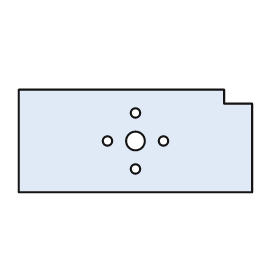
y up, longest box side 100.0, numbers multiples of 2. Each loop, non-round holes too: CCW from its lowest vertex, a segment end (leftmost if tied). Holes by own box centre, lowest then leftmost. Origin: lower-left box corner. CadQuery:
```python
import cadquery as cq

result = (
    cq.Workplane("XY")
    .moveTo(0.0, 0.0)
    .lineTo(100.0, 0.0)
    .lineTo(100.0, 38.0)
    .lineTo(88.0, 38.0)
    .lineTo(88.0, 44.0)
    .lineTo(0.0, 44.0)
    .close()
    .moveTo(50.0, 10.0)
    .circle(2.0)
    .moveTo(38.0, 22.0)
    .circle(2.0)
    .moveTo(50.0, 22.0)
    .circle(4.0)
    .moveTo(62.0, 22.0)
    .circle(2.0)
    .moveTo(50.0, 34.0)
    .circle(2.0)
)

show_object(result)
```